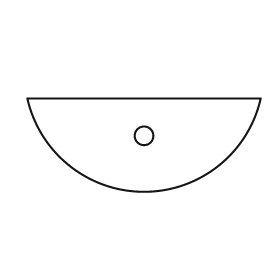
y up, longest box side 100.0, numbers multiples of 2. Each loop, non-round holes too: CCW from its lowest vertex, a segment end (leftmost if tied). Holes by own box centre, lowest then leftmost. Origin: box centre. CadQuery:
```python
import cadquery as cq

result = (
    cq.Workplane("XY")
    .moveTo(-50.0, 20.0)
    .threePointArc((0.0, -20.0), (50.0, 20.0))
    .close()
    .moveTo(0.0, 4.0)
    .circle(4.0)
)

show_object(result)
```